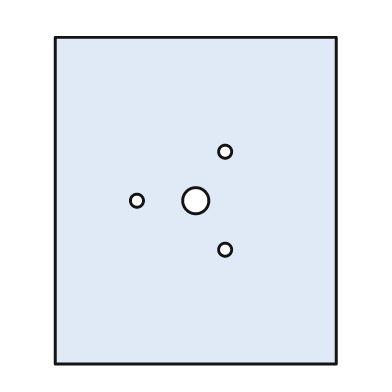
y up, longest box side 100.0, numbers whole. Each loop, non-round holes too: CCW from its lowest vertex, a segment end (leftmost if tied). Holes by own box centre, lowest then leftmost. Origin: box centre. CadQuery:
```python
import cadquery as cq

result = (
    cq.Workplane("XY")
    .moveTo(-43.0, -50.0)
    .lineTo(43.0, -50.0)
    .lineTo(43.0, 50.0)
    .lineTo(-43.0, 50.0)
    .close()
    .moveTo(9.0, -15.0)
    .circle(2.0)
    .moveTo(-18.0, 0.0)
    .circle(2.0)
    .moveTo(0.0, 0.0)
    .circle(4.0)
    .moveTo(9.0, 15.0)
    .circle(2.0)
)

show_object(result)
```